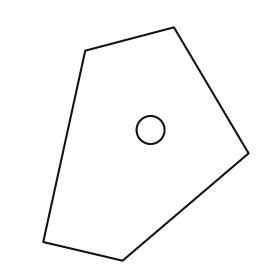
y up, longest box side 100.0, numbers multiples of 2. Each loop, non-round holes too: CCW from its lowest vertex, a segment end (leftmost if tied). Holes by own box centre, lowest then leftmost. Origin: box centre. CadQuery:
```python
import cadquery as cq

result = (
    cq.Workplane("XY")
    .moveTo(-10.0, -50.0)
    .lineTo(44.0, -4.0)
    .lineTo(12.0, 50.0)
    .lineTo(-26.0, 40.0)
    .lineTo(-44.0, -42.0)
    .close()
    .moveTo(2.0, 6.0)
    .circle(6.0)
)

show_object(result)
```